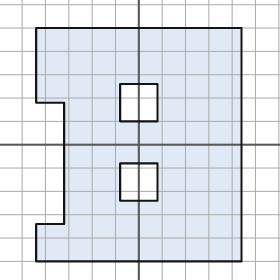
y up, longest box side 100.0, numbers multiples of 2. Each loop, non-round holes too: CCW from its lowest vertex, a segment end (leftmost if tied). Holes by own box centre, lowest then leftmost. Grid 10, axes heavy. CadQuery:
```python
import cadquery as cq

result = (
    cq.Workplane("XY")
    .moveTo(-44.0, -50.0)
    .lineTo(44.0, -50.0)
    .lineTo(44.0, 50.0)
    .lineTo(-44.0, 50.0)
    .lineTo(-44.0, 18.0)
    .lineTo(-32.0, 18.0)
    .lineTo(-32.0, -34.0)
    .lineTo(-44.0, -34.0)
    .close()
    .moveTo(-8.0, -24.0)
    .lineTo(8.0, -24.0)
    .lineTo(8.0, -8.0)
    .lineTo(-8.0, -8.0)
    .close()
    .moveTo(-8.0, 10.0)
    .lineTo(8.0, 10.0)
    .lineTo(8.0, 26.0)
    .lineTo(-8.0, 26.0)
    .close()
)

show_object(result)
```